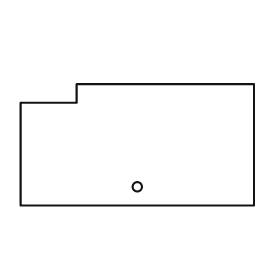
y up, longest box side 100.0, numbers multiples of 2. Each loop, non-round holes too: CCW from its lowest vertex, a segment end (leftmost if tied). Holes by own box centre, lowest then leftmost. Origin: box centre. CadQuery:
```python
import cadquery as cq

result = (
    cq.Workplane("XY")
    .moveTo(-50.0, -26.0)
    .lineTo(50.0, -26.0)
    .lineTo(50.0, 26.0)
    .lineTo(-26.0, 26.0)
    .lineTo(-26.0, 18.0)
    .lineTo(-50.0, 18.0)
    .close()
    .moveTo(0.0, -18.0)
    .circle(2.0)
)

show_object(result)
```